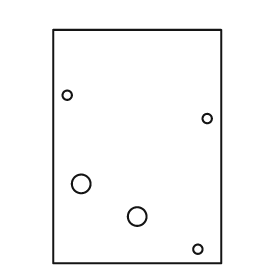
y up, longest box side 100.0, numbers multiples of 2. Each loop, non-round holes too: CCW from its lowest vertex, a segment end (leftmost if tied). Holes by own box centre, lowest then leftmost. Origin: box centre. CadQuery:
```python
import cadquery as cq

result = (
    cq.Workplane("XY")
    .moveTo(-36.0, -50.0)
    .lineTo(36.0, -50.0)
    .lineTo(36.0, 50.0)
    .lineTo(-36.0, 50.0)
    .close()
    .moveTo(26.0, -44.0)
    .circle(2.0)
    .moveTo(0.0, -30.0)
    .circle(4.0)
    .moveTo(-24.0, -16.0)
    .circle(4.0)
    .moveTo(30.0, 12.0)
    .circle(2.0)
    .moveTo(-30.0, 22.0)
    .circle(2.0)
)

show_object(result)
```